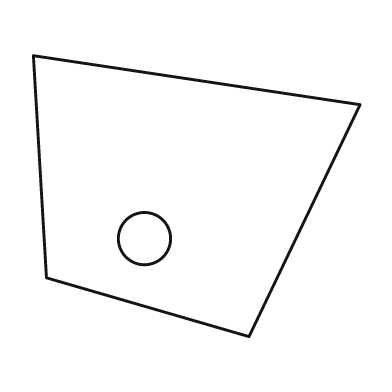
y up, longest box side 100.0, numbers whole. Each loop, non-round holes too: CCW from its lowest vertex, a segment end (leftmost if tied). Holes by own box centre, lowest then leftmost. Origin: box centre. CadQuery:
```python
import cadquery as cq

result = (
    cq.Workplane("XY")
    .moveTo(16.0, -43.0)
    .lineTo(50.0, 28.0)
    .lineTo(-50.0, 43.0)
    .lineTo(-46.0, -25.0)
    .close()
    .moveTo(-16.0, -13.0)
    .circle(8.0)
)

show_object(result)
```